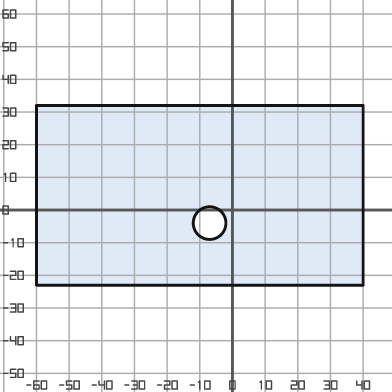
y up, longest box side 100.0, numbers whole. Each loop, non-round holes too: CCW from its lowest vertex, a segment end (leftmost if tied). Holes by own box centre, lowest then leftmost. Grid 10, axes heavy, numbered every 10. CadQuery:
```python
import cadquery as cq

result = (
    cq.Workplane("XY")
    .moveTo(-60.0, -23.0)
    .lineTo(40.0, -23.0)
    .lineTo(40.0, 32.0)
    .lineTo(-60.0, 32.0)
    .close()
    .moveTo(-7.0, -4.0)
    .circle(5.0)
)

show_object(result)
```